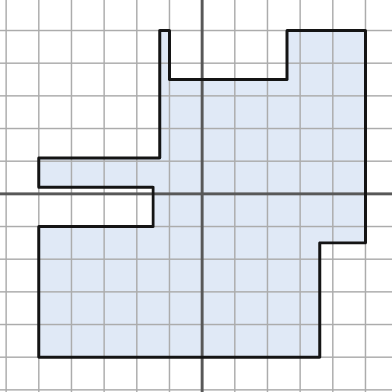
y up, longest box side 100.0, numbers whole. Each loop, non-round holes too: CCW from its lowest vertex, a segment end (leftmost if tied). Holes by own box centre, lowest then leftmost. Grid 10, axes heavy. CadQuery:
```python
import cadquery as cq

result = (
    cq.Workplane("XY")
    .moveTo(-50.0, -50.0)
    .lineTo(36.0, -50.0)
    .lineTo(36.0, -15.0)
    .lineTo(50.0, -15.0)
    .lineTo(50.0, 50.0)
    .lineTo(26.0, 50.0)
    .lineTo(26.0, 35.0)
    .lineTo(-10.0, 35.0)
    .lineTo(-10.0, 50.0)
    .lineTo(-13.0, 50.0)
    .lineTo(-13.0, 11.0)
    .lineTo(-50.0, 11.0)
    .lineTo(-50.0, 2.0)
    .lineTo(-15.0, 2.0)
    .lineTo(-15.0, -10.0)
    .lineTo(-50.0, -10.0)
    .close()
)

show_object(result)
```